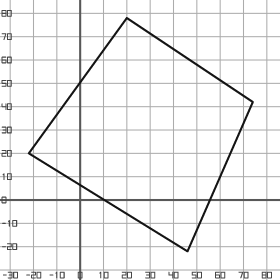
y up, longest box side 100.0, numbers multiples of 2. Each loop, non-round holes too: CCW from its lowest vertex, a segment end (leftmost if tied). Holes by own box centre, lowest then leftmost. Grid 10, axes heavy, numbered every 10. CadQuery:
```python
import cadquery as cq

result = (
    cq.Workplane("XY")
    .moveTo(46.0, -22.0)
    .lineTo(74.0, 42.0)
    .lineTo(20.0, 78.0)
    .lineTo(-22.0, 20.0)
    .close()
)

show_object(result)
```